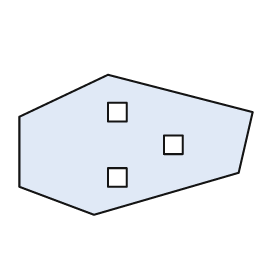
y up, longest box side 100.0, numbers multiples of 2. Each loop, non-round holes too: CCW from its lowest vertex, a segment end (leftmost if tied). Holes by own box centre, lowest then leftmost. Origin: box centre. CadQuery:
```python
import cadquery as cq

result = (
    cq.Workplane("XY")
    .moveTo(-18.0, -30.0)
    .lineTo(44.0, -12.0)
    .lineTo(50.0, 14.0)
    .lineTo(-12.0, 30.0)
    .lineTo(-50.0, 12.0)
    .lineTo(-50.0, -18.0)
    .close()
    .moveTo(-12.0, -18.0)
    .lineTo(-4.0, -18.0)
    .lineTo(-4.0, -10.0)
    .lineTo(-12.0, -10.0)
    .close()
    .moveTo(12.0, -4.0)
    .lineTo(20.0, -4.0)
    .lineTo(20.0, 4.0)
    .lineTo(12.0, 4.0)
    .close()
    .moveTo(-12.0, 10.0)
    .lineTo(-4.0, 10.0)
    .lineTo(-4.0, 18.0)
    .lineTo(-12.0, 18.0)
    .close()
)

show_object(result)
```